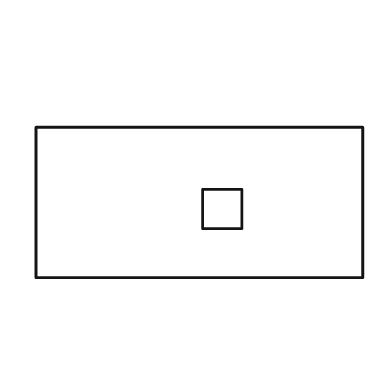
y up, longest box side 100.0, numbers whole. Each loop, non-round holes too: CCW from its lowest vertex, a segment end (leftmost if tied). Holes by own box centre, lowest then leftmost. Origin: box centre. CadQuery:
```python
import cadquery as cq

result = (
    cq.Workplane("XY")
    .moveTo(-50.0, -23.0)
    .lineTo(50.0, -23.0)
    .lineTo(50.0, 23.0)
    .lineTo(-50.0, 23.0)
    .close()
    .moveTo(1.0, -8.0)
    .lineTo(13.0, -8.0)
    .lineTo(13.0, 4.0)
    .lineTo(1.0, 4.0)
    .close()
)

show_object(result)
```